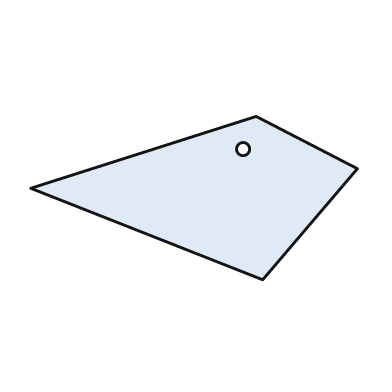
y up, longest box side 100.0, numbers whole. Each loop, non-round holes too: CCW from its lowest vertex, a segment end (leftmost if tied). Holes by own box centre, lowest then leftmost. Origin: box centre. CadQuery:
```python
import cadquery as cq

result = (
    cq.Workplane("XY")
    .moveTo(21.0, -25.0)
    .lineTo(50.0, 9.0)
    .lineTo(19.0, 25.0)
    .lineTo(-50.0, 3.0)
    .close()
    .moveTo(15.0, 15.0)
    .circle(2.0)
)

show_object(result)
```